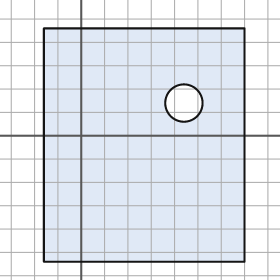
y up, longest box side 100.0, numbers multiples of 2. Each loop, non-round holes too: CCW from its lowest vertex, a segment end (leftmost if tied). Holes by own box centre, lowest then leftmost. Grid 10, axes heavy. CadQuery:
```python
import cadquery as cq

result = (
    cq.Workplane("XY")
    .moveTo(-16.0, -54.0)
    .lineTo(70.0, -54.0)
    .lineTo(70.0, 46.0)
    .lineTo(-16.0, 46.0)
    .close()
    .moveTo(44.0, 14.0)
    .circle(8.0)
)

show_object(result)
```